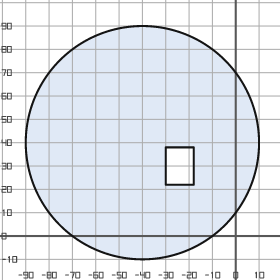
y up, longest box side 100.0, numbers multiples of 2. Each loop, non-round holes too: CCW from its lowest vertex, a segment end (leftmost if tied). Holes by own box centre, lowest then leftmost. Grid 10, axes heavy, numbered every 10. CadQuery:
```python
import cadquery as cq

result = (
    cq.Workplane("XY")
    .moveTo(-40.0, 40.0)
    .circle(50.0)
    .moveTo(-30.0, 22.0)
    .lineTo(-18.0, 22.0)
    .lineTo(-18.0, 38.0)
    .lineTo(-30.0, 38.0)
    .close()
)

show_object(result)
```